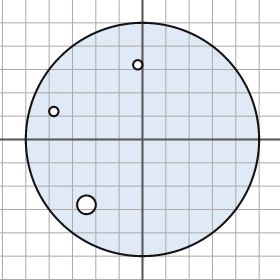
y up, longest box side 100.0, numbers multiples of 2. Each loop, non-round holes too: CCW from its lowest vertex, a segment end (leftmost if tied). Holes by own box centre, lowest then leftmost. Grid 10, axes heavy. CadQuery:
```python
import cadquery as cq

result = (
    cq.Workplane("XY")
    .moveTo(0.0, 0.0)
    .circle(50.0)
    .moveTo(-24.0, -28.0)
    .circle(4.0)
    .moveTo(-38.0, 12.0)
    .circle(2.0)
    .moveTo(-2.0, 32.0)
    .circle(2.0)
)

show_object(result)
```